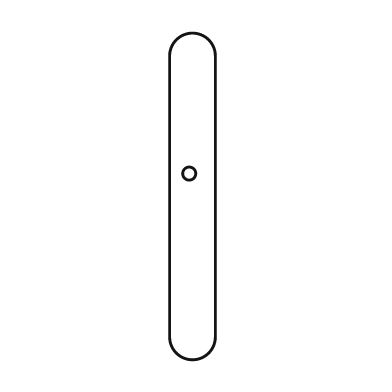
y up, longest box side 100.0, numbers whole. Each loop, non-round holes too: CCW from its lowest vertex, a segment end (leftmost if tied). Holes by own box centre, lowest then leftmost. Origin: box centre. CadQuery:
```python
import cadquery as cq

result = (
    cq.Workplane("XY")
    .moveTo(-7.0, -43.0)
    .threePointArc((0.0, -50.0), (7.0, -43.0))
    .lineTo(7.0, 43.0)
    .threePointArc((0.0, 50.0), (-7.0, 43.0))
    .close()
    .moveTo(-1.0, 7.0)
    .circle(2.0)
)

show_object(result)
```